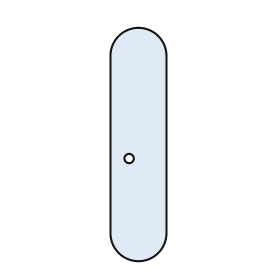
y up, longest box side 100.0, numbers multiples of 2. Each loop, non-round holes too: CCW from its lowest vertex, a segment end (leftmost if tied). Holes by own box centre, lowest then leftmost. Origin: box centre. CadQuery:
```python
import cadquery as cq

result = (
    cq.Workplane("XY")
    .moveTo(-12.0, -38.0)
    .threePointArc((0.0, -50.0), (12.0, -38.0))
    .lineTo(12.0, 38.0)
    .threePointArc((0.0, 50.0), (-12.0, 38.0))
    .close()
    .moveTo(-4.0, -6.0)
    .circle(2.0)
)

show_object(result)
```